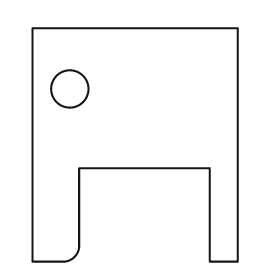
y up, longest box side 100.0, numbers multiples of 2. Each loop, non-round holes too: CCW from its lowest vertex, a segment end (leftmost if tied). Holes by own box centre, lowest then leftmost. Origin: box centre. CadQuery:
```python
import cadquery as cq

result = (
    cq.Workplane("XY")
    .moveTo(-44.0, -50.0)
    .lineTo(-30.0, -50.0)
    .threePointArc((-26.0, -48.0), (-24.0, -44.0))
    .lineTo(-24.0, -10.0)
    .lineTo(32.0, -10.0)
    .lineTo(32.0, -50.0)
    .lineTo(44.0, -50.0)
    .lineTo(44.0, 50.0)
    .lineTo(-44.0, 50.0)
    .close()
    .moveTo(-28.0, 24.0)
    .circle(8.0)
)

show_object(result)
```